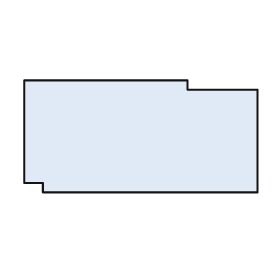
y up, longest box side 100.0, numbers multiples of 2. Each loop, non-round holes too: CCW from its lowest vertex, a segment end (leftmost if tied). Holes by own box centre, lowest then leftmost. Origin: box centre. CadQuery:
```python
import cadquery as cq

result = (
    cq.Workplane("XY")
    .moveTo(-42.0, -24.0)
    .lineTo(50.0, -24.0)
    .lineTo(50.0, 20.0)
    .lineTo(20.0, 20.0)
    .lineTo(20.0, 24.0)
    .lineTo(-50.0, 24.0)
    .lineTo(-50.0, -20.0)
    .lineTo(-42.0, -20.0)
    .close()
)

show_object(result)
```